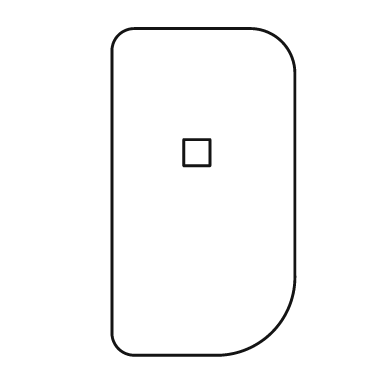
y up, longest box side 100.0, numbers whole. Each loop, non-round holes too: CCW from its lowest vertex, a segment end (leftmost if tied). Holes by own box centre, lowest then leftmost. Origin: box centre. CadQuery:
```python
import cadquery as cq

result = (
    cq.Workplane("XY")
    .moveTo(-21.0, -50.0)
    .lineTo(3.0, -50.0)
    .threePointArc((21.0, -43.0), (28.0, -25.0))
    .lineTo(28.0, 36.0)
    .threePointArc((24.0, 46.0), (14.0, 50.0))
    .lineTo(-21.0, 50.0)
    .threePointArc((-26.0, 48.0), (-28.0, 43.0))
    .lineTo(-28.0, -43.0)
    .threePointArc((-26.0, -48.0), (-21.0, -50.0))
    .close()
    .moveTo(-6.0, 8.0)
    .lineTo(2.0, 8.0)
    .lineTo(2.0, 16.0)
    .lineTo(-6.0, 16.0)
    .close()
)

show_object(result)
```